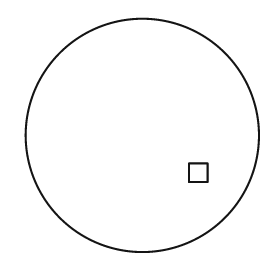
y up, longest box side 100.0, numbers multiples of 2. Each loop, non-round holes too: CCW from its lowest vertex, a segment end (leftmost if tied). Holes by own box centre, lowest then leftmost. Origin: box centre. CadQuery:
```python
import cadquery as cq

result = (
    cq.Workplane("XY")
    .moveTo(0.0, 0.0)
    .circle(50.0)
    .moveTo(20.0, -20.0)
    .lineTo(28.0, -20.0)
    .lineTo(28.0, -12.0)
    .lineTo(20.0, -12.0)
    .close()
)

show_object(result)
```